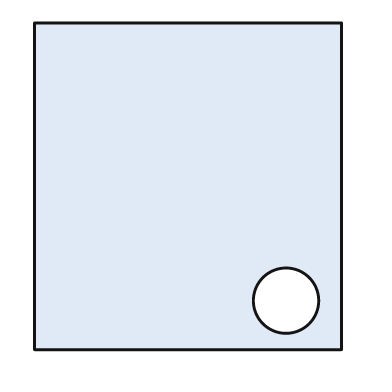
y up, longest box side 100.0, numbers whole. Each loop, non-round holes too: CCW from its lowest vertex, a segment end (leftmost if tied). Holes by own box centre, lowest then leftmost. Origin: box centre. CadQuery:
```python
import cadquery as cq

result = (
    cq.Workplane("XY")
    .moveTo(-47.0, -50.0)
    .lineTo(47.0, -50.0)
    .lineTo(47.0, 50.0)
    .lineTo(-47.0, 50.0)
    .close()
    .moveTo(30.0, -35.0)
    .circle(10.0)
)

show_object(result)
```